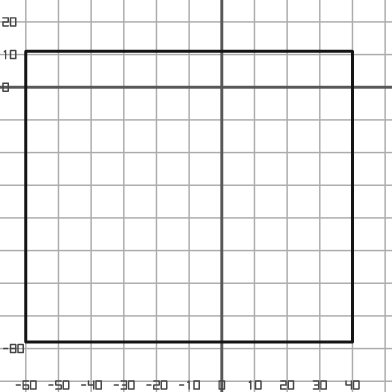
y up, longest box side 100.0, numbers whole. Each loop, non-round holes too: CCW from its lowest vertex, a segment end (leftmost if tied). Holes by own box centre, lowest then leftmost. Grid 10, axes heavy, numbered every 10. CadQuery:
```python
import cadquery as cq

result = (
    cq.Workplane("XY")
    .moveTo(-60.0, -78.0)
    .lineTo(40.0, -78.0)
    .lineTo(40.0, 11.0)
    .lineTo(-60.0, 11.0)
    .close()
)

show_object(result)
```